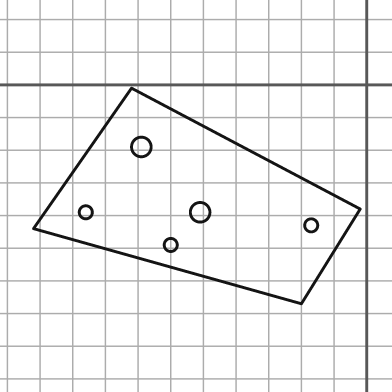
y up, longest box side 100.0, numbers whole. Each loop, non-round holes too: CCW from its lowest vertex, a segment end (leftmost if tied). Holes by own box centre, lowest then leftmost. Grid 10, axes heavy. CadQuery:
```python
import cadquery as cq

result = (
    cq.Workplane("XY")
    .moveTo(-20.0, -67.0)
    .lineTo(-2.0, -38.0)
    .lineTo(-72.0, -1.0)
    .lineTo(-102.0, -44.0)
    .close()
    .moveTo(-60.0, -49.0)
    .circle(2.0)
    .moveTo(-17.0, -43.0)
    .circle(2.0)
    .moveTo(-86.0, -39.0)
    .circle(2.0)
    .moveTo(-51.0, -39.0)
    .circle(3.0)
    .moveTo(-69.0, -19.0)
    .circle(3.0)
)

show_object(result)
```